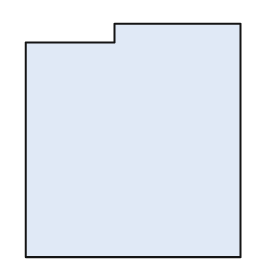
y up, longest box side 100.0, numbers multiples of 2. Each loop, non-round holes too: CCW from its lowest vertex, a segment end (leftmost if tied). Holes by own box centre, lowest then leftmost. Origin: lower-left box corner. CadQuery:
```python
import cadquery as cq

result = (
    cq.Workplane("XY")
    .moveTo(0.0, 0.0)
    .lineTo(92.0, 0.0)
    .lineTo(92.0, 100.0)
    .lineTo(38.0, 100.0)
    .lineTo(38.0, 92.0)
    .lineTo(0.0, 92.0)
    .close()
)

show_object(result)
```